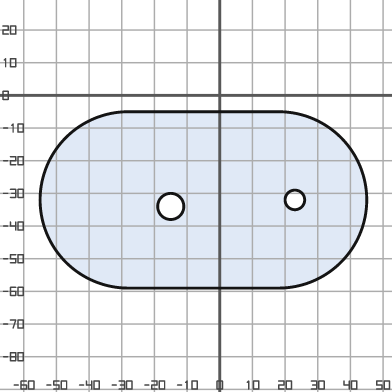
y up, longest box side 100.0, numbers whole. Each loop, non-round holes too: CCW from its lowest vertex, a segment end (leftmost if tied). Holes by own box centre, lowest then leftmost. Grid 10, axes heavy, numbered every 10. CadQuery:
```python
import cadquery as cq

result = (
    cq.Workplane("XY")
    .moveTo(-28.0, -59.0)
    .lineTo(18.0, -59.0)
    .threePointArc((45.0, -32.0), (18.0, -5.0))
    .lineTo(-28.0, -5.0)
    .threePointArc((-55.0, -32.0), (-28.0, -59.0))
    .close()
    .moveTo(-15.0, -34.0)
    .circle(4.0)
    .moveTo(23.0, -32.0)
    .circle(3.0)
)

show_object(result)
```